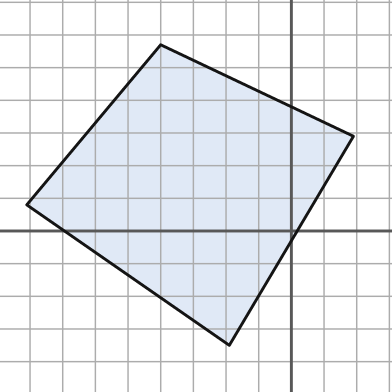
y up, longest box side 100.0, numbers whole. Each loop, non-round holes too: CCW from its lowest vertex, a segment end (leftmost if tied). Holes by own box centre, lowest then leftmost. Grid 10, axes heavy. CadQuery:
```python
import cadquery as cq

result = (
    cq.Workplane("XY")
    .moveTo(-19.0, -35.0)
    .lineTo(19.0, 29.0)
    .lineTo(-40.0, 57.0)
    .lineTo(-81.0, 8.0)
    .close()
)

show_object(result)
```